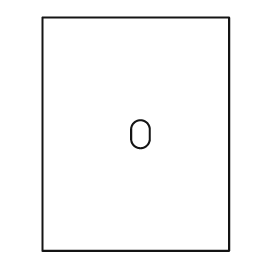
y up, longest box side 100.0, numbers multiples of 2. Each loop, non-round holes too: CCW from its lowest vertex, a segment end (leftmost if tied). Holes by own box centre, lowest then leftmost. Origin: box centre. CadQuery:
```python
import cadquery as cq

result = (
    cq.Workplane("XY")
    .moveTo(-40.0, -50.0)
    .lineTo(40.0, -50.0)
    .lineTo(40.0, 50.0)
    .lineTo(-40.0, 50.0)
    .close()
    .moveTo(-2.0, -2.0)
    .threePointArc((2.0, -6.0), (6.0, -2.0))
    .lineTo(6.0, 2.0)
    .threePointArc((2.0, 6.0), (-2.0, 2.0))
    .close()
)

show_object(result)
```